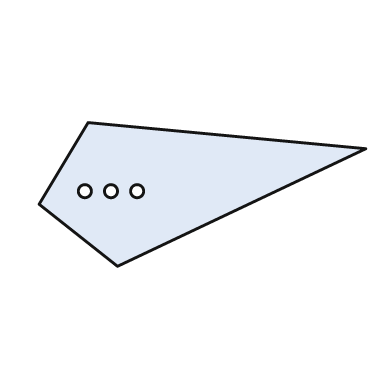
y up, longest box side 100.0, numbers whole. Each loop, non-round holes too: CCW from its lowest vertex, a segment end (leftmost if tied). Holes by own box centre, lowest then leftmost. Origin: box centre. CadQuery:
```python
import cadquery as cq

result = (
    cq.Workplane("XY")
    .moveTo(-26.0, -22.0)
    .lineTo(50.0, 14.0)
    .lineTo(-35.0, 22.0)
    .lineTo(-50.0, -3.0)
    .close()
    .moveTo(-36.0, 1.0)
    .circle(2.0)
    .moveTo(-28.0, 1.0)
    .circle(2.0)
    .moveTo(-20.0, 1.0)
    .circle(2.0)
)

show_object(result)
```